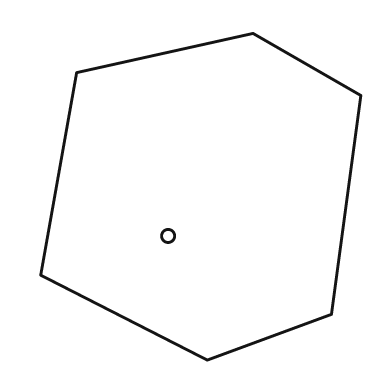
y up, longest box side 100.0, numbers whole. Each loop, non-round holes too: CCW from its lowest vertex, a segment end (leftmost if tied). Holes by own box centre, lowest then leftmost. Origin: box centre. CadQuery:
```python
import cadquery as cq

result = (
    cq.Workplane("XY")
    .moveTo(2.0, -50.0)
    .lineTo(40.0, -36.0)
    .lineTo(49.0, 31.0)
    .lineTo(16.0, 50.0)
    .lineTo(-38.0, 38.0)
    .lineTo(-49.0, -24.0)
    .close()
    .moveTo(-10.0, -12.0)
    .circle(2.0)
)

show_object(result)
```